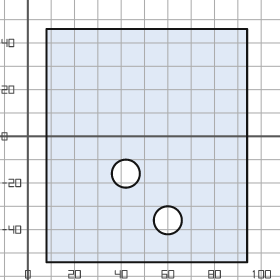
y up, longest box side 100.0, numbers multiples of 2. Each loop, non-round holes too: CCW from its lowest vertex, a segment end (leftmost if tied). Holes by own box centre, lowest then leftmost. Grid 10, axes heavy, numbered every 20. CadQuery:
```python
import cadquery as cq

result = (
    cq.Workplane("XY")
    .moveTo(8.0, -54.0)
    .lineTo(94.0, -54.0)
    .lineTo(94.0, 46.0)
    .lineTo(8.0, 46.0)
    .close()
    .moveTo(60.0, -36.0)
    .circle(6.0)
    .moveTo(42.0, -16.0)
    .circle(6.0)
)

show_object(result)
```